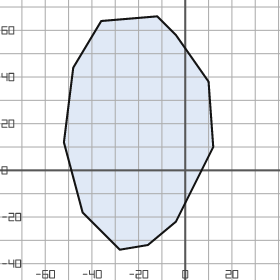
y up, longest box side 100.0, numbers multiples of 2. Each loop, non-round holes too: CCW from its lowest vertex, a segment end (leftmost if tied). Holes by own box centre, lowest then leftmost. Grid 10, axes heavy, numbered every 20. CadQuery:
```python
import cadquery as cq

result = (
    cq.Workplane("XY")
    .moveTo(-28.0, -34.0)
    .lineTo(-16.0, -32.0)
    .lineTo(-4.0, -22.0)
    .lineTo(12.0, 10.0)
    .lineTo(10.0, 38.0)
    .lineTo(-4.0, 58.0)
    .lineTo(-12.0, 66.0)
    .lineTo(-36.0, 64.0)
    .lineTo(-48.0, 44.0)
    .lineTo(-52.0, 12.0)
    .lineTo(-44.0, -18.0)
    .close()
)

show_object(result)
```